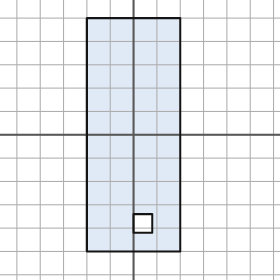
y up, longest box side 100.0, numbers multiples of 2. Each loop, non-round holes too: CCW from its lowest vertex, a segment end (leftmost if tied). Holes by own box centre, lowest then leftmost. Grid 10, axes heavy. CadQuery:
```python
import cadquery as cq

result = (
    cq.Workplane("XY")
    .moveTo(-20.0, -50.0)
    .lineTo(20.0, -50.0)
    .lineTo(20.0, 50.0)
    .lineTo(-20.0, 50.0)
    .close()
    .moveTo(0.0, -42.0)
    .lineTo(8.0, -42.0)
    .lineTo(8.0, -34.0)
    .lineTo(0.0, -34.0)
    .close()
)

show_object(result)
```